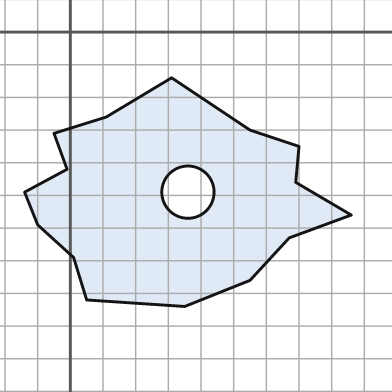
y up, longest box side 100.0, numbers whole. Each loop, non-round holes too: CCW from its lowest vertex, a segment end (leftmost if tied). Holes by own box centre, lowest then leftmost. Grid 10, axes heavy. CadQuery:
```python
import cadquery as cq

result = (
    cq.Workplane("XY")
    .moveTo(35.0, -84.0)
    .lineTo(55.0, -76.0)
    .lineTo(67.0, -63.0)
    .lineTo(86.0, -56.0)
    .lineTo(69.0, -46.0)
    .lineTo(70.0, -35.0)
    .lineTo(55.0, -30.0)
    .lineTo(31.0, -14.0)
    .lineTo(11.0, -26.0)
    .lineTo(-5.0, -31.0)
    .lineTo(-1.0, -42.0)
    .lineTo(-14.0, -49.0)
    .lineTo(-10.0, -59.0)
    .lineTo(1.0, -69.0)
    .lineTo(5.0, -82.0)
    .close()
    .moveTo(36.0, -49.0)
    .circle(8.0)
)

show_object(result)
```